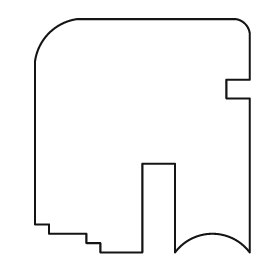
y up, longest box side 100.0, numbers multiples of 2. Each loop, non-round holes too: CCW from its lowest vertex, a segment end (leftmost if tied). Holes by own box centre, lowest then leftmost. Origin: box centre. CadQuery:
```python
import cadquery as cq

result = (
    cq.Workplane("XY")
    .moveTo(-18.0, -50.0)
    .lineTo(0.0, -50.0)
    .lineTo(0.0, -12.0)
    .lineTo(14.0, -12.0)
    .lineTo(14.0, -50.0)
    .threePointArc((30.0, -42.0), (46.0, -50.0))
    .lineTo(46.0, 16.0)
    .lineTo(36.0, 16.0)
    .lineTo(36.0, 24.0)
    .lineTo(46.0, 24.0)
    .lineTo(46.0, 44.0)
    .threePointArc((44.0, 48.0), (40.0, 50.0))
    .lineTo(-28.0, 50.0)
    .threePointArc((-40.0, 44.0), (-46.0, 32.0))
    .lineTo(-46.0, -38.0)
    .lineTo(-40.0, -38.0)
    .lineTo(-40.0, -42.0)
    .lineTo(-24.0, -42.0)
    .lineTo(-24.0, -46.0)
    .lineTo(-18.0, -46.0)
    .close()
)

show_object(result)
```